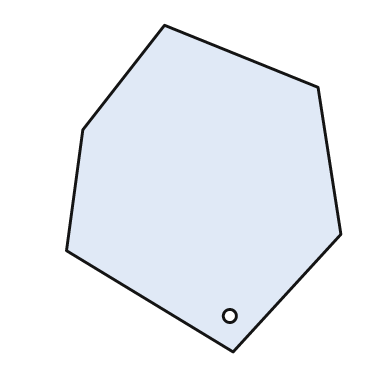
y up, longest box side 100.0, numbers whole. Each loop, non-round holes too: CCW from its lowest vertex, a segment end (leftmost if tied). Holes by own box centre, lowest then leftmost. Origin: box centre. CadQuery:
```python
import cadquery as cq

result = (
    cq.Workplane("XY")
    .moveTo(9.0, -50.0)
    .lineTo(42.0, -14.0)
    .lineTo(35.0, 31.0)
    .lineTo(-12.0, 50.0)
    .lineTo(-37.0, 18.0)
    .lineTo(-42.0, -19.0)
    .close()
    .moveTo(8.0, -39.0)
    .circle(2.0)
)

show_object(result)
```